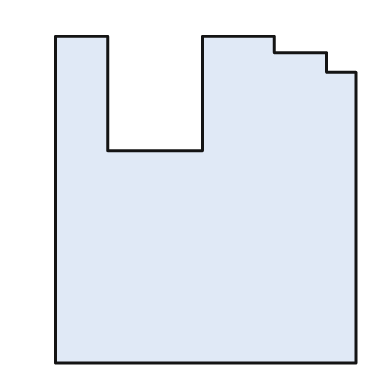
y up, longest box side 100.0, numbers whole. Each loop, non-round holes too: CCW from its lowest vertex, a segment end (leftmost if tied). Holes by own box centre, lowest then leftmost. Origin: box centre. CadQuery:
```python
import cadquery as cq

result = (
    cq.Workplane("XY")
    .moveTo(-46.0, -50.0)
    .lineTo(46.0, -50.0)
    .lineTo(46.0, 39.0)
    .lineTo(37.0, 39.0)
    .lineTo(37.0, 45.0)
    .lineTo(21.0, 45.0)
    .lineTo(21.0, 50.0)
    .lineTo(-1.0, 50.0)
    .lineTo(-1.0, 15.0)
    .lineTo(-30.0, 15.0)
    .lineTo(-30.0, 50.0)
    .lineTo(-46.0, 50.0)
    .close()
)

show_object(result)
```